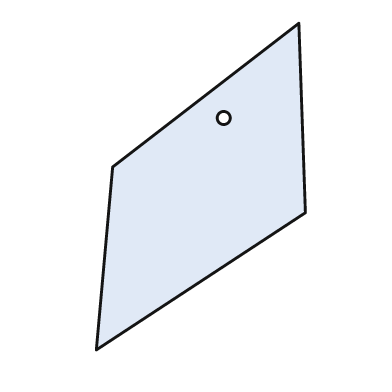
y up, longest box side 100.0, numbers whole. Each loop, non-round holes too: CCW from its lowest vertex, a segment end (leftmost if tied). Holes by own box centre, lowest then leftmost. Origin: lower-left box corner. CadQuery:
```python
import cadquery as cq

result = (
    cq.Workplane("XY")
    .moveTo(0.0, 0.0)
    .lineTo(64.0, 42.0)
    .lineTo(62.0, 100.0)
    .lineTo(5.0, 56.0)
    .close()
    .moveTo(39.0, 71.0)
    .circle(2.0)
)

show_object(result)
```